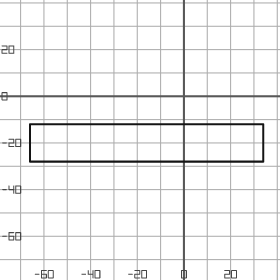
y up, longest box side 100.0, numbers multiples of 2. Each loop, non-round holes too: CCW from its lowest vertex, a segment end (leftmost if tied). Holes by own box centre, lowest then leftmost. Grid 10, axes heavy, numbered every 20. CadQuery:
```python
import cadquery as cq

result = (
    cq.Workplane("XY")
    .moveTo(-66.0, -28.0)
    .lineTo(34.0, -28.0)
    .lineTo(34.0, -12.0)
    .lineTo(-66.0, -12.0)
    .close()
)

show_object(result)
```